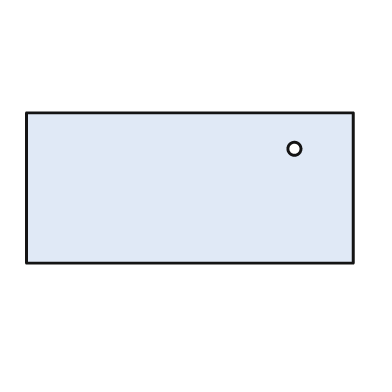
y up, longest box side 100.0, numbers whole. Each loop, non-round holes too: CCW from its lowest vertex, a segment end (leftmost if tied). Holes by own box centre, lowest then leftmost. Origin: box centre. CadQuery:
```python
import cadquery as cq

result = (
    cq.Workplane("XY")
    .moveTo(-50.0, -23.0)
    .lineTo(50.0, -23.0)
    .lineTo(50.0, 23.0)
    .lineTo(-50.0, 23.0)
    .close()
    .moveTo(32.0, 12.0)
    .circle(2.0)
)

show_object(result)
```